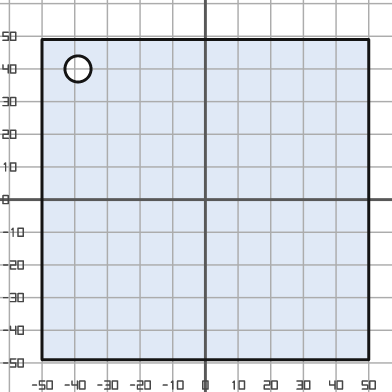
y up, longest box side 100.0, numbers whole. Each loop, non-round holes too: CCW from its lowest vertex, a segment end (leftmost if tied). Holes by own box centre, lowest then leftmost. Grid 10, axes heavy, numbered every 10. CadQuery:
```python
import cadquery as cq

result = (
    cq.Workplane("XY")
    .moveTo(-50.0, -49.0)
    .lineTo(50.0, -49.0)
    .lineTo(50.0, 49.0)
    .lineTo(-50.0, 49.0)
    .close()
    .moveTo(-39.0, 40.0)
    .circle(4.0)
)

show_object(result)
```